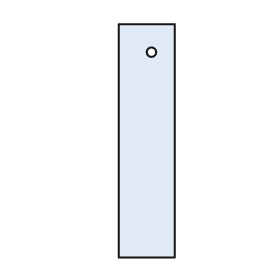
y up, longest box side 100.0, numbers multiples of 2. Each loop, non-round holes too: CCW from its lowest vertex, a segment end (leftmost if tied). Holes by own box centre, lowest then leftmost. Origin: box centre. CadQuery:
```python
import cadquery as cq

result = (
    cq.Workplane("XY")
    .moveTo(-12.0, -50.0)
    .lineTo(12.0, -50.0)
    .lineTo(12.0, 50.0)
    .lineTo(-12.0, 50.0)
    .close()
    .moveTo(2.0, 38.0)
    .circle(2.0)
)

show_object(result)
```